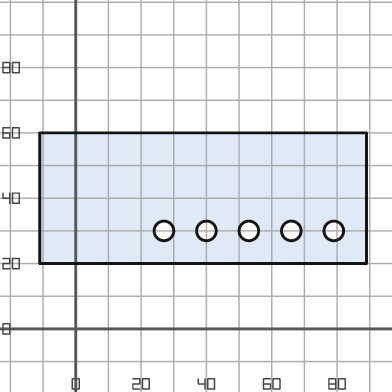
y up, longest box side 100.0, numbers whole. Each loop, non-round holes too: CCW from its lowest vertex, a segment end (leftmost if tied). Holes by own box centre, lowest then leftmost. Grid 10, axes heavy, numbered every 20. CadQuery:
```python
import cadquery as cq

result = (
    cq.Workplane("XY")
    .moveTo(-11.0, 20.0)
    .lineTo(89.0, 20.0)
    .lineTo(89.0, 60.0)
    .lineTo(-11.0, 60.0)
    .close()
    .moveTo(27.0, 30.0)
    .circle(3.0)
    .moveTo(40.0, 30.0)
    .circle(3.0)
    .moveTo(53.0, 30.0)
    .circle(3.0)
    .moveTo(66.0, 30.0)
    .circle(3.0)
    .moveTo(79.0, 30.0)
    .circle(3.0)
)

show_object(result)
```